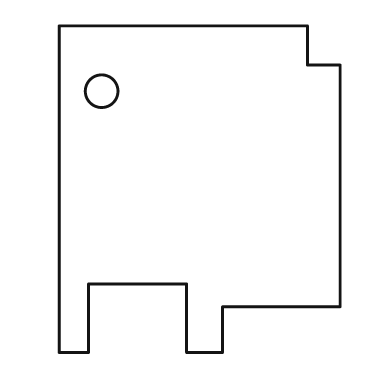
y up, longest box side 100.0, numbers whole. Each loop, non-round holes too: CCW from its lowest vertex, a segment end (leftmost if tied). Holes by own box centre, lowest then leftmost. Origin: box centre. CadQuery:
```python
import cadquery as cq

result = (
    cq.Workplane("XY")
    .moveTo(-43.0, -50.0)
    .lineTo(-34.0, -50.0)
    .lineTo(-34.0, -29.0)
    .lineTo(-4.0, -29.0)
    .lineTo(-4.0, -50.0)
    .lineTo(7.0, -50.0)
    .lineTo(7.0, -36.0)
    .lineTo(43.0, -36.0)
    .lineTo(43.0, 38.0)
    .lineTo(33.0, 38.0)
    .lineTo(33.0, 50.0)
    .lineTo(-43.0, 50.0)
    .close()
    .moveTo(-30.0, 30.0)
    .circle(5.0)
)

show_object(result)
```